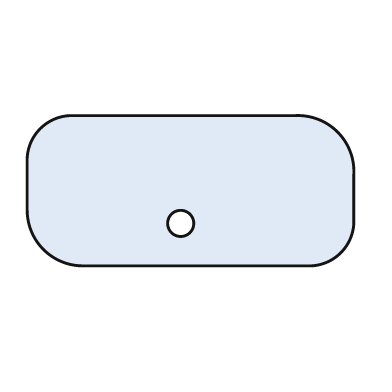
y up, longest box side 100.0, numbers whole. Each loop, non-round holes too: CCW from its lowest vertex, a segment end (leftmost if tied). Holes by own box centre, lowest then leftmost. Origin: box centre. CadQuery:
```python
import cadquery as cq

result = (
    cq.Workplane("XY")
    .moveTo(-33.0, -23.0)
    .lineTo(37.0, -23.0)
    .threePointArc((46.0, -19.0), (50.0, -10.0))
    .lineTo(50.0, 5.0)
    .threePointArc((45.0, 18.0), (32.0, 23.0))
    .lineTo(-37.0, 23.0)
    .threePointArc((-46.0, 19.0), (-50.0, 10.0))
    .lineTo(-50.0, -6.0)
    .threePointArc((-45.0, -18.0), (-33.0, -23.0))
    .close()
    .moveTo(-3.0, -10.0)
    .circle(4.0)
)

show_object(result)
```